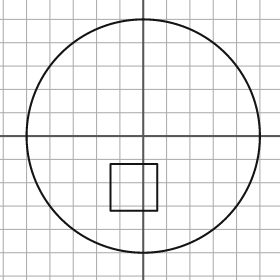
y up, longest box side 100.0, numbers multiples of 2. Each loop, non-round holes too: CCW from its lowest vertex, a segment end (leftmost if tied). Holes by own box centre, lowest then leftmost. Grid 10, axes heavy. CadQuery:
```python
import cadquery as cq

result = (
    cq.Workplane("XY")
    .moveTo(0.0, 0.0)
    .circle(50.0)
    .moveTo(-14.0, -32.0)
    .lineTo(6.0, -32.0)
    .lineTo(6.0, -12.0)
    .lineTo(-14.0, -12.0)
    .close()
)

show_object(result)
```